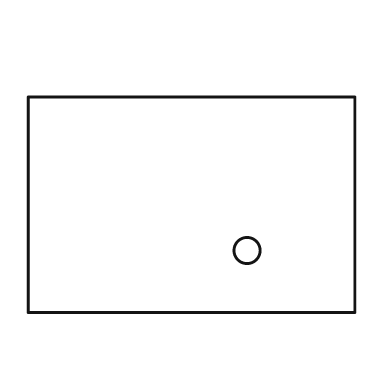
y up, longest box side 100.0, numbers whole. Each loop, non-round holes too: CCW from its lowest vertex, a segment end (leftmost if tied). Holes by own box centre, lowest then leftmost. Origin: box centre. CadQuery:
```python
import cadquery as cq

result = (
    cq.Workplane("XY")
    .moveTo(-50.0, -33.0)
    .lineTo(50.0, -33.0)
    .lineTo(50.0, 33.0)
    .lineTo(-50.0, 33.0)
    .close()
    .moveTo(17.0, -14.0)
    .circle(4.0)
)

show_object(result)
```